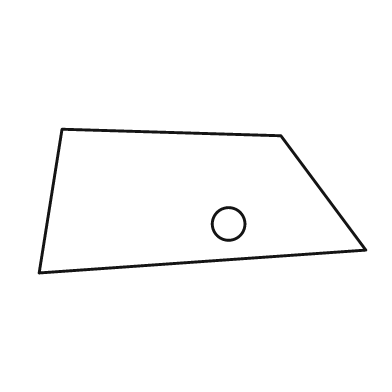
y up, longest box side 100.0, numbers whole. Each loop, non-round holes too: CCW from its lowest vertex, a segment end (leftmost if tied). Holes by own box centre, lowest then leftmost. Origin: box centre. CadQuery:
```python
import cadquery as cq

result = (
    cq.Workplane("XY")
    .moveTo(-50.0, -22.0)
    .lineTo(50.0, -15.0)
    .lineTo(24.0, 20.0)
    .lineTo(-43.0, 22.0)
    .close()
    .moveTo(8.0, -7.0)
    .circle(5.0)
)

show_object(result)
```